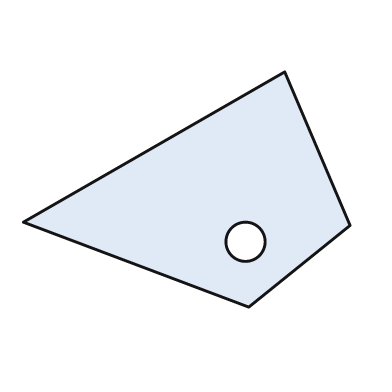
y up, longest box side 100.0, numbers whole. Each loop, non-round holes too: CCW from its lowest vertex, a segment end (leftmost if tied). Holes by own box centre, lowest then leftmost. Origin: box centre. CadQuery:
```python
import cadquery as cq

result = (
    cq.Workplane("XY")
    .moveTo(19.0, -36.0)
    .lineTo(50.0, -11.0)
    .lineTo(30.0, 36.0)
    .lineTo(-50.0, -10.0)
    .close()
    .moveTo(18.0, -16.0)
    .circle(6.0)
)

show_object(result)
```